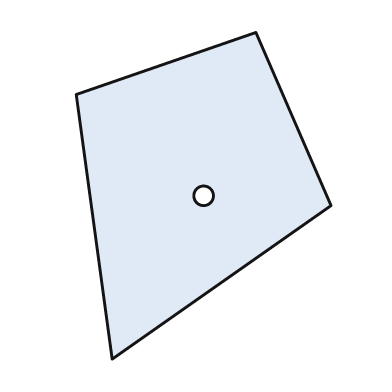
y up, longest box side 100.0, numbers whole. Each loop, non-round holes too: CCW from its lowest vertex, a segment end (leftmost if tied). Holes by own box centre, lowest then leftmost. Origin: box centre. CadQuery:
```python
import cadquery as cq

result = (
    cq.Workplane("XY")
    .moveTo(-28.0, -50.0)
    .lineTo(39.0, -3.0)
    .lineTo(16.0, 50.0)
    .lineTo(-39.0, 31.0)
    .close()
    .moveTo(0.0, 0.0)
    .circle(3.0)
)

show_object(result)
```